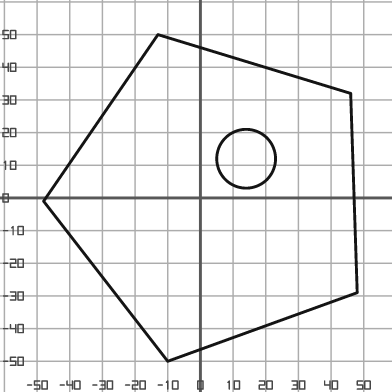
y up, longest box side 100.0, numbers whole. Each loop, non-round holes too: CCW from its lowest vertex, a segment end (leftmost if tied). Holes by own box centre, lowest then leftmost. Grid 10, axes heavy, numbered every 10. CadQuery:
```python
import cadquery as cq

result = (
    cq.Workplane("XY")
    .moveTo(-10.0, -50.0)
    .lineTo(48.0, -29.0)
    .lineTo(46.0, 32.0)
    .lineTo(-13.0, 50.0)
    .lineTo(-48.0, -1.0)
    .close()
    .moveTo(14.0, 12.0)
    .circle(9.0)
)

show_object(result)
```